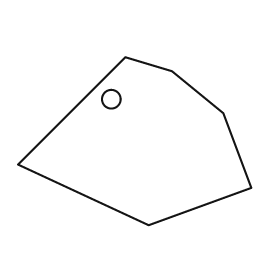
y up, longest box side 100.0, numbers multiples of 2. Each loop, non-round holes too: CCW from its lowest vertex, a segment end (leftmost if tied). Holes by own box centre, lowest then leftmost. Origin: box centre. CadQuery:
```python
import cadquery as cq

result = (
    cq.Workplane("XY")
    .moveTo(6.0, -36.0)
    .lineTo(50.0, -20.0)
    .lineTo(38.0, 12.0)
    .lineTo(16.0, 30.0)
    .lineTo(-4.0, 36.0)
    .lineTo(-50.0, -10.0)
    .close()
    .moveTo(-10.0, 18.0)
    .circle(4.0)
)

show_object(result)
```